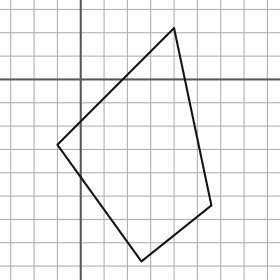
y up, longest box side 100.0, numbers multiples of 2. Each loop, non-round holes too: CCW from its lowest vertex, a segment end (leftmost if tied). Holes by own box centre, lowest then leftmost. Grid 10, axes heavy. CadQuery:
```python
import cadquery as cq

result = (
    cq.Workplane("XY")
    .moveTo(26.0, -78.0)
    .lineTo(56.0, -54.0)
    .lineTo(40.0, 22.0)
    .lineTo(-10.0, -28.0)
    .close()
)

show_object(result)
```